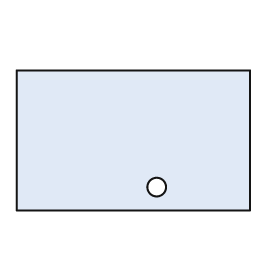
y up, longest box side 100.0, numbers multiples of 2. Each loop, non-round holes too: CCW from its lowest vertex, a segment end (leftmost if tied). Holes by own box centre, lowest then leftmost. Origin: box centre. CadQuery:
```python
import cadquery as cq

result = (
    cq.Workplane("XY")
    .moveTo(-50.0, -30.0)
    .lineTo(50.0, -30.0)
    .lineTo(50.0, 30.0)
    .lineTo(-50.0, 30.0)
    .close()
    .moveTo(10.0, -20.0)
    .circle(4.0)
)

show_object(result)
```